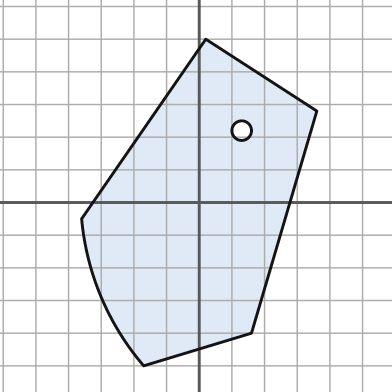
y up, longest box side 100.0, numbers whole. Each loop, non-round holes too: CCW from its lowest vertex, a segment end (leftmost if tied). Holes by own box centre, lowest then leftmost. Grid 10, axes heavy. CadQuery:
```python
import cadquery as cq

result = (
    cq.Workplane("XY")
    .moveTo(-17.0, -50.0)
    .lineTo(16.0, -40.0)
    .lineTo(36.0, 28.0)
    .lineTo(2.0, 50.0)
    .lineTo(-36.0, -5.0)
    .threePointArc((-30.0, -29.0), (-17.0, -50.0))
    .close()
    .moveTo(13.0, 22.0)
    .circle(3.0)
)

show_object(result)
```